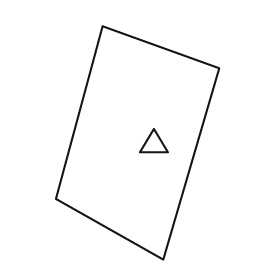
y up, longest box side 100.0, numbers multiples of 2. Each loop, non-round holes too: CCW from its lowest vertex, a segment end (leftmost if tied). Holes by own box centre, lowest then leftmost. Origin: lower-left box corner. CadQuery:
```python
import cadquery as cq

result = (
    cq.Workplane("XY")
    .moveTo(46.0, 0.0)
    .lineTo(70.0, 82.0)
    .lineTo(20.0, 100.0)
    .lineTo(0.0, 26.0)
    .close()
    .moveTo(36.0, 46.0)
    .lineTo(48.0, 46.0)
    .lineTo(42.0, 56.0)
    .close()
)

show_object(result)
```